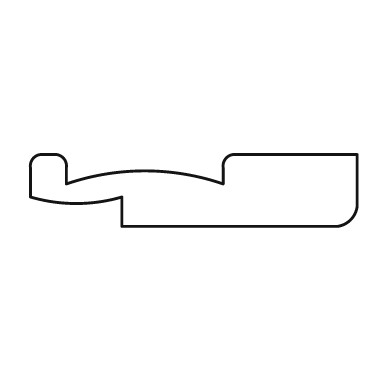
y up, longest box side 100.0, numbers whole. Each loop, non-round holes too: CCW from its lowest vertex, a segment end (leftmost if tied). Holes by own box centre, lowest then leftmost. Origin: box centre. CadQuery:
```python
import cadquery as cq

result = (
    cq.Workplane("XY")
    .moveTo(-22.0, -11.0)
    .lineTo(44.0, -11.0)
    .threePointArc((48.0, -9.0), (50.0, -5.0))
    .lineTo(50.0, 11.0)
    .lineTo(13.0, 11.0)
    .threePointArc((10.0, 10.0), (9.0, 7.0))
    .lineTo(9.0, 2.0)
    .threePointArc((-15.0, 6.0), (-39.0, 2.0))
    .lineTo(-39.0, 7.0)
    .threePointArc((-40.0, 10.0), (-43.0, 11.0))
    .lineTo(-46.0, 11.0)
    .threePointArc((-49.0, 10.0), (-50.0, 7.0))
    .lineTo(-50.0, -2.0)
    .threePointArc((-36.0, -4.0), (-22.0, -2.0))
    .close()
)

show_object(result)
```